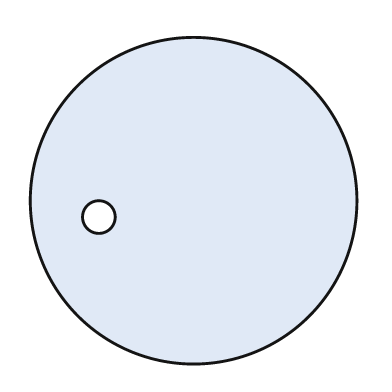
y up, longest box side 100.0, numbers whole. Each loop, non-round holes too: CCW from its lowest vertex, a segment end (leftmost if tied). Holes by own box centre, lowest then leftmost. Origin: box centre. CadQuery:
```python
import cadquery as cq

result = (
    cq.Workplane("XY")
    .moveTo(0.0, 0.0)
    .circle(50.0)
    .moveTo(-29.0, -5.0)
    .circle(5.0)
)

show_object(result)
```